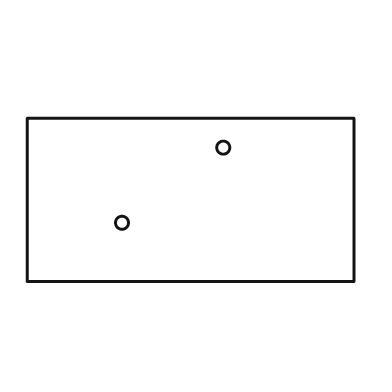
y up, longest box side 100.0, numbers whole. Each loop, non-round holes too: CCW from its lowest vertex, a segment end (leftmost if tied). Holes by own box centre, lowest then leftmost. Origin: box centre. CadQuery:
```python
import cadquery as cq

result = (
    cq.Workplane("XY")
    .moveTo(-50.0, -25.0)
    .lineTo(50.0, -25.0)
    .lineTo(50.0, 25.0)
    .lineTo(-50.0, 25.0)
    .close()
    .moveTo(-21.0, -7.0)
    .circle(2.0)
    .moveTo(10.0, 16.0)
    .circle(2.0)
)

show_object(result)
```